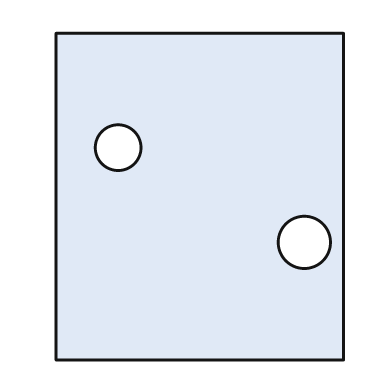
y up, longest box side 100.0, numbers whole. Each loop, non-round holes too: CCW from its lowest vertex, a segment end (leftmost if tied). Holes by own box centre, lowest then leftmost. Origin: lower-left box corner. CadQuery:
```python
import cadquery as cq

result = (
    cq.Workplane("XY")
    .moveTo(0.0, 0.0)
    .lineTo(88.0, 0.0)
    .lineTo(88.0, 100.0)
    .lineTo(0.0, 100.0)
    .close()
    .moveTo(76.0, 36.0)
    .circle(8.0)
    .moveTo(19.0, 65.0)
    .circle(7.0)
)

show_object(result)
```